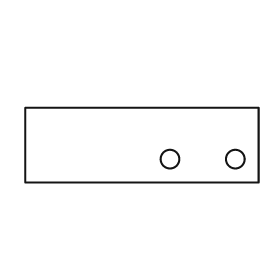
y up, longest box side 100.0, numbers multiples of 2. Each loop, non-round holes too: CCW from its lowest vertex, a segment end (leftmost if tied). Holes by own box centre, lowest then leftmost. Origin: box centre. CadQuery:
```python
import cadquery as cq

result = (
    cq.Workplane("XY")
    .moveTo(-50.0, -16.0)
    .lineTo(50.0, -16.0)
    .lineTo(50.0, 16.0)
    .lineTo(-50.0, 16.0)
    .close()
    .moveTo(12.0, -6.0)
    .circle(4.0)
    .moveTo(40.0, -6.0)
    .circle(4.0)
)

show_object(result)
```